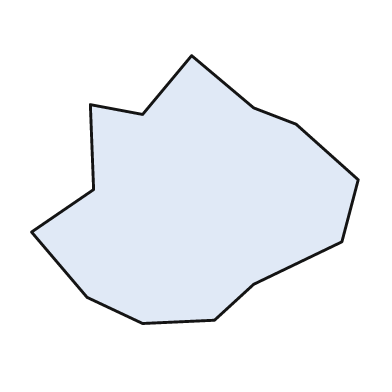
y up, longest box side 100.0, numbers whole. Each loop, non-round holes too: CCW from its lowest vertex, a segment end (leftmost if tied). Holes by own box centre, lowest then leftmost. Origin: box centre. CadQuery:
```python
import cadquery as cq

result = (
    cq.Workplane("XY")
    .moveTo(-16.0, -41.0)
    .lineTo(6.0, -40.0)
    .lineTo(18.0, -29.0)
    .lineTo(45.0, -16.0)
    .lineTo(50.0, 3.0)
    .lineTo(31.0, 20.0)
    .lineTo(18.0, 25.0)
    .lineTo(-1.0, 41.0)
    .lineTo(-16.0, 23.0)
    .lineTo(-32.0, 26.0)
    .lineTo(-31.0, 0.0)
    .lineTo(-50.0, -13.0)
    .lineTo(-33.0, -33.0)
    .close()
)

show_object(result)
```